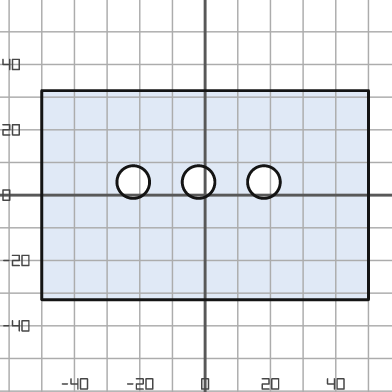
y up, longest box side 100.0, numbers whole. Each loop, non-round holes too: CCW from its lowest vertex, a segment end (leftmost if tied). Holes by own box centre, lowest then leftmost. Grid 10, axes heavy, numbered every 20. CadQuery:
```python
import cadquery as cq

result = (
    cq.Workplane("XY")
    .moveTo(-50.0, -32.0)
    .lineTo(50.0, -32.0)
    .lineTo(50.0, 32.0)
    .lineTo(-50.0, 32.0)
    .close()
    .moveTo(-22.0, 4.0)
    .circle(5.0)
    .moveTo(-2.0, 4.0)
    .circle(5.0)
    .moveTo(18.0, 4.0)
    .circle(5.0)
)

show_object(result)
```